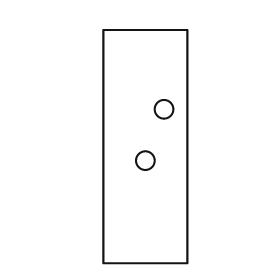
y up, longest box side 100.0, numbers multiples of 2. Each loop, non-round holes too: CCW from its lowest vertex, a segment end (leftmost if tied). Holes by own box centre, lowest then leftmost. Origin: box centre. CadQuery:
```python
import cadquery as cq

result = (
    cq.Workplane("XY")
    .moveTo(-18.0, -50.0)
    .lineTo(18.0, -50.0)
    .lineTo(18.0, 50.0)
    .lineTo(-18.0, 50.0)
    .close()
    .moveTo(0.0, -6.0)
    .circle(4.0)
    .moveTo(8.0, 16.0)
    .circle(4.0)
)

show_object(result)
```